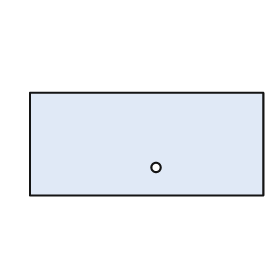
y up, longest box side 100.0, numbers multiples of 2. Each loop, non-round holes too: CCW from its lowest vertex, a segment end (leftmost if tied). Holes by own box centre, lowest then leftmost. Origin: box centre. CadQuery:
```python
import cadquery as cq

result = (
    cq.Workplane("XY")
    .moveTo(-50.0, -22.0)
    .lineTo(50.0, -22.0)
    .lineTo(50.0, 22.0)
    .lineTo(-50.0, 22.0)
    .close()
    .moveTo(4.0, -10.0)
    .circle(2.0)
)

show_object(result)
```